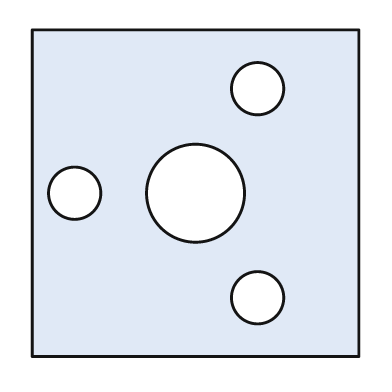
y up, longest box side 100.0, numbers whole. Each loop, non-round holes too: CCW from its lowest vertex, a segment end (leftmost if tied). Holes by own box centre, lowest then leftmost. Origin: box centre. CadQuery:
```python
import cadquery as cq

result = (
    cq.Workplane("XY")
    .moveTo(-50.0, -50.0)
    .lineTo(50.0, -50.0)
    .lineTo(50.0, 50.0)
    .lineTo(-50.0, 50.0)
    .close()
    .moveTo(19.0, -32.0)
    .circle(8.0)
    .moveTo(-37.0, 0.0)
    .circle(8.0)
    .moveTo(0.0, 0.0)
    .circle(15.0)
    .moveTo(19.0, 32.0)
    .circle(8.0)
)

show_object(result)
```